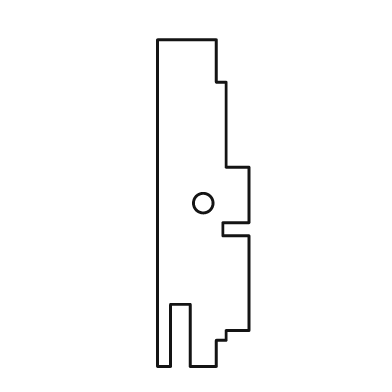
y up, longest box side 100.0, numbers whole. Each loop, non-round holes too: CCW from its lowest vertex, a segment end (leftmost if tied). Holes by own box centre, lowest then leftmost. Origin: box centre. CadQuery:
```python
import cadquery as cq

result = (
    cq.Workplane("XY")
    .moveTo(-14.0, -50.0)
    .lineTo(-10.0, -50.0)
    .lineTo(-10.0, -31.0)
    .lineTo(-4.0, -31.0)
    .lineTo(-4.0, -50.0)
    .lineTo(4.0, -50.0)
    .lineTo(4.0, -42.0)
    .lineTo(7.0, -42.0)
    .lineTo(7.0, -39.0)
    .lineTo(14.0, -39.0)
    .lineTo(14.0, -10.0)
    .lineTo(6.0, -10.0)
    .lineTo(6.0, -6.0)
    .lineTo(14.0, -6.0)
    .lineTo(14.0, 11.0)
    .lineTo(7.0, 11.0)
    .lineTo(7.0, 37.0)
    .lineTo(4.0, 37.0)
    .lineTo(4.0, 50.0)
    .lineTo(-14.0, 50.0)
    .close()
    .moveTo(0.0, 0.0)
    .circle(3.0)
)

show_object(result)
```